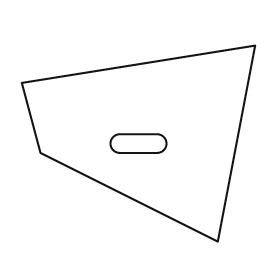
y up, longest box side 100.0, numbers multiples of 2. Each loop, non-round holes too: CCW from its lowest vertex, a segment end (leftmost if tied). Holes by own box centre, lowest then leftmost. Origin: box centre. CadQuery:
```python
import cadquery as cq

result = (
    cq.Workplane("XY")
    .moveTo(34.0, -42.0)
    .lineTo(50.0, 42.0)
    .lineTo(-50.0, 26.0)
    .lineTo(-42.0, -4.0)
    .close()
    .moveTo(-8.0, -4.0)
    .lineTo(8.0, -4.0)
    .threePointArc((12.0, 0.0), (8.0, 4.0))
    .lineTo(-8.0, 4.0)
    .threePointArc((-12.0, 0.0), (-8.0, -4.0))
    .close()
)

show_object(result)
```